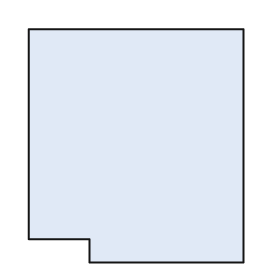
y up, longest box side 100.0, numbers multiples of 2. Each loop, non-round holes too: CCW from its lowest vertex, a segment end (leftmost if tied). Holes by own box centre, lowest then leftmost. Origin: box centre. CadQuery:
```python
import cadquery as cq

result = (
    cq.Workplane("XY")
    .moveTo(-20.0, -50.0)
    .lineTo(46.0, -50.0)
    .lineTo(46.0, 50.0)
    .lineTo(-46.0, 50.0)
    .lineTo(-46.0, -40.0)
    .lineTo(-20.0, -40.0)
    .close()
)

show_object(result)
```